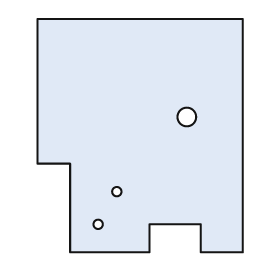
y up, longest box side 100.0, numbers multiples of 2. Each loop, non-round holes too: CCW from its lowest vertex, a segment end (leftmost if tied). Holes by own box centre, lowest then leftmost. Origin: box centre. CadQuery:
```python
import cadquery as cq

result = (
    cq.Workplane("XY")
    .moveTo(-30.0, -50.0)
    .lineTo(4.0, -50.0)
    .lineTo(4.0, -38.0)
    .lineTo(26.0, -38.0)
    .lineTo(26.0, -50.0)
    .lineTo(44.0, -50.0)
    .lineTo(44.0, 50.0)
    .lineTo(-44.0, 50.0)
    .lineTo(-44.0, -12.0)
    .lineTo(-30.0, -12.0)
    .close()
    .moveTo(-18.0, -38.0)
    .circle(2.0)
    .moveTo(-10.0, -24.0)
    .circle(2.0)
    .moveTo(20.0, 8.0)
    .circle(4.0)
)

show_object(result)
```